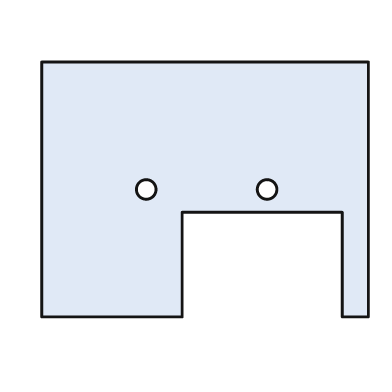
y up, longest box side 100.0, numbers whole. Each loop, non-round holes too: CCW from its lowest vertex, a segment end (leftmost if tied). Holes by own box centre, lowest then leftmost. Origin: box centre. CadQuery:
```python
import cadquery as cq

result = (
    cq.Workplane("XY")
    .moveTo(-50.0, -39.0)
    .lineTo(-7.0, -39.0)
    .lineTo(-7.0, -7.0)
    .lineTo(42.0, -7.0)
    .lineTo(42.0, -39.0)
    .lineTo(50.0, -39.0)
    .lineTo(50.0, 39.0)
    .lineTo(-50.0, 39.0)
    .close()
    .moveTo(-18.0, 0.0)
    .circle(3.0)
    .moveTo(19.0, 0.0)
    .circle(3.0)
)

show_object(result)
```